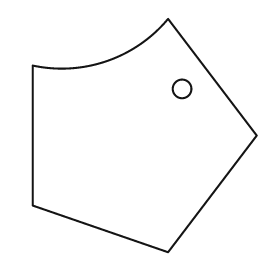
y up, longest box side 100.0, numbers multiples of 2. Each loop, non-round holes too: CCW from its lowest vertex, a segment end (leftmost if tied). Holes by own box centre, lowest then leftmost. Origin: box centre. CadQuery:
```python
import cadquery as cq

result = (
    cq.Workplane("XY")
    .moveTo(10.0, -50.0)
    .lineTo(48.0, 0.0)
    .lineTo(10.0, 50.0)
    .threePointArc((-16.0, 32.0), (-48.0, 30.0))
    .lineTo(-48.0, -30.0)
    .close()
    .moveTo(16.0, 20.0)
    .circle(4.0)
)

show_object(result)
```